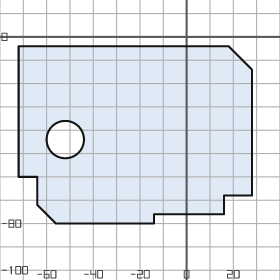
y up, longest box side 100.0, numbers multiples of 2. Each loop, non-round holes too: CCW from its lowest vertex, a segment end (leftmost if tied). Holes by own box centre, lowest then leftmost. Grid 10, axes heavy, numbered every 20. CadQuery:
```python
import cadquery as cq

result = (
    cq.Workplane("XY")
    .moveTo(-56.0, -80.0)
    .lineTo(-14.0, -80.0)
    .lineTo(-14.0, -76.0)
    .lineTo(16.0, -76.0)
    .lineTo(16.0, -68.0)
    .lineTo(28.0, -68.0)
    .lineTo(28.0, -14.0)
    .lineTo(18.0, -4.0)
    .lineTo(-72.0, -4.0)
    .lineTo(-72.0, -60.0)
    .lineTo(-64.0, -60.0)
    .lineTo(-64.0, -72.0)
    .close()
    .moveTo(-52.0, -44.0)
    .circle(8.0)
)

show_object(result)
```